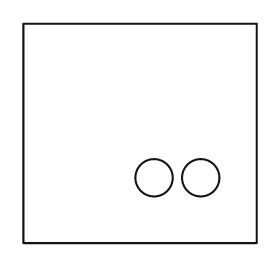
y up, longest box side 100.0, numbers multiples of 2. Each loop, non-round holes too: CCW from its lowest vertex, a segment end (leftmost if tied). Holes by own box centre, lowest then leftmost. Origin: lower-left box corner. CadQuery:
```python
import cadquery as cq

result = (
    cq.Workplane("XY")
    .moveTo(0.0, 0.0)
    .lineTo(100.0, 0.0)
    .lineTo(100.0, 94.0)
    .lineTo(0.0, 94.0)
    .close()
    .moveTo(56.0, 28.0)
    .circle(8.0)
    .moveTo(76.0, 28.0)
    .circle(8.0)
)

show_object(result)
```